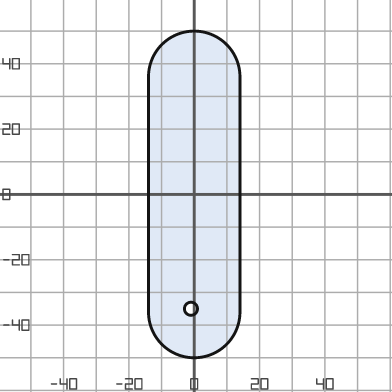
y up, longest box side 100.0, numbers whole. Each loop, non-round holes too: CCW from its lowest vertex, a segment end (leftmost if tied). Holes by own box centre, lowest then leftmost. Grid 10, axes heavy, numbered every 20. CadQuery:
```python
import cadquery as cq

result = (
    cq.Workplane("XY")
    .moveTo(-14.0, -36.0)
    .threePointArc((0.0, -50.0), (14.0, -36.0))
    .lineTo(14.0, 36.0)
    .threePointArc((0.0, 50.0), (-14.0, 36.0))
    .close()
    .moveTo(-1.0, -35.0)
    .circle(2.0)
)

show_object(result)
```